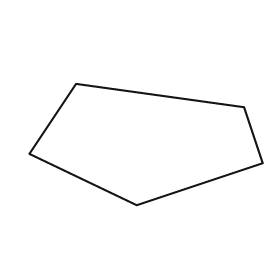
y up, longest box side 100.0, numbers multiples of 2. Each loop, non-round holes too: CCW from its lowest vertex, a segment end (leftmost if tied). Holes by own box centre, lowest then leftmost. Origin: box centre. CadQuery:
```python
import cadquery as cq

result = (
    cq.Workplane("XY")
    .moveTo(-4.0, -26.0)
    .lineTo(50.0, -8.0)
    .lineTo(42.0, 16.0)
    .lineTo(-30.0, 26.0)
    .lineTo(-50.0, -4.0)
    .close()
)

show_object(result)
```